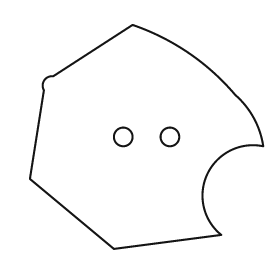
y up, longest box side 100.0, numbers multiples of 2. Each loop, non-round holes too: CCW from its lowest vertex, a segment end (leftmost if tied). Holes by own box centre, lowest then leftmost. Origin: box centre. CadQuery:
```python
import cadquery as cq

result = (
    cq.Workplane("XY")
    .moveTo(-14.0, -48.0)
    .lineTo(32.0, -42.0)
    .threePointArc((26.0, -16.0), (50.0, -4.0))
    .threePointArc((46.0, 8.0), (38.0, 18.0))
    .threePointArc((18.0, 36.0), (-6.0, 48.0))
    .lineTo(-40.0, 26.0)
    .threePointArc((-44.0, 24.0), (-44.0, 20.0))
    .lineTo(-50.0, -18.0)
    .close()
    .moveTo(-10.0, 0.0)
    .circle(4.0)
    .moveTo(10.0, 0.0)
    .circle(4.0)
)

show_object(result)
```